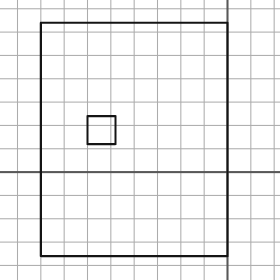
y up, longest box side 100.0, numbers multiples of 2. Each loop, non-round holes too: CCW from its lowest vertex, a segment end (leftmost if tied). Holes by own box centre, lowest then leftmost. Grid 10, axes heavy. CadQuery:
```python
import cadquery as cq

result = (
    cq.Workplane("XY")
    .moveTo(-80.0, -36.0)
    .lineTo(0.0, -36.0)
    .lineTo(0.0, 64.0)
    .lineTo(-80.0, 64.0)
    .close()
    .moveTo(-60.0, 12.0)
    .lineTo(-48.0, 12.0)
    .lineTo(-48.0, 24.0)
    .lineTo(-60.0, 24.0)
    .close()
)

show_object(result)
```